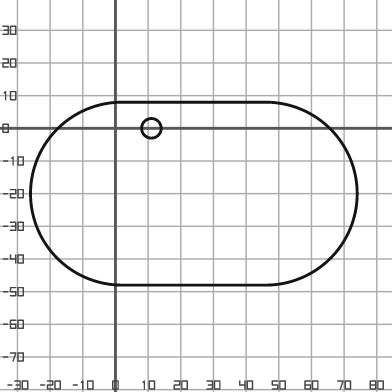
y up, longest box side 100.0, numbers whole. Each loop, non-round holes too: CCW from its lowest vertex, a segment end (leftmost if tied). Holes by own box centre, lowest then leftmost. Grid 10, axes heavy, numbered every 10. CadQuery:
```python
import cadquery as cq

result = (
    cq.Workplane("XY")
    .moveTo(2.0, -48.0)
    .lineTo(46.0, -48.0)
    .threePointArc((74.0, -20.0), (46.0, 8.0))
    .lineTo(2.0, 8.0)
    .threePointArc((-26.0, -20.0), (2.0, -48.0))
    .close()
    .moveTo(11.0, 0.0)
    .circle(3.0)
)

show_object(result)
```